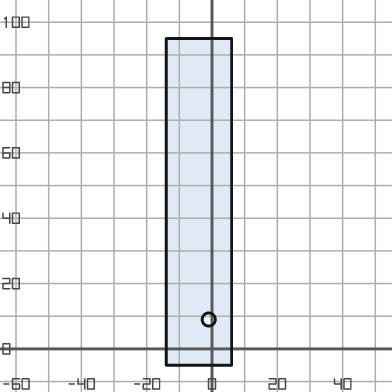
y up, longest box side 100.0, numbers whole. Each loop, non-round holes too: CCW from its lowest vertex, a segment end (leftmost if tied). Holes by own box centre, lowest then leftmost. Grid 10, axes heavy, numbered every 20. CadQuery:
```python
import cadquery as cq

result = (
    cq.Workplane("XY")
    .moveTo(-14.0, -5.0)
    .lineTo(6.0, -5.0)
    .lineTo(6.0, 95.0)
    .lineTo(-14.0, 95.0)
    .close()
    .moveTo(-1.0, 9.0)
    .circle(2.0)
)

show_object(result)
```